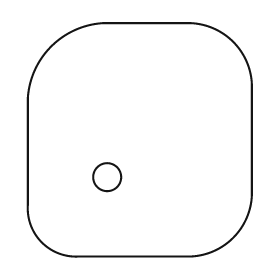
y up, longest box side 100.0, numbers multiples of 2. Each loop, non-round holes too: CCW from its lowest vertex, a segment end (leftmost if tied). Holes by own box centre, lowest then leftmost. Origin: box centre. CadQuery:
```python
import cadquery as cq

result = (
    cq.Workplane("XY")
    .moveTo(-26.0, -50.0)
    .lineTo(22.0, -50.0)
    .threePointArc((40.0, -42.0), (48.0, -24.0))
    .lineTo(48.0, 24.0)
    .threePointArc((40.0, 42.0), (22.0, 50.0))
    .lineTo(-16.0, 50.0)
    .threePointArc((-38.0, 40.0), (-48.0, 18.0))
    .lineTo(-48.0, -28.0)
    .threePointArc((-42.0, -44.0), (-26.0, -50.0))
    .close()
    .moveTo(-14.0, -16.0)
    .circle(6.0)
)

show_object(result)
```